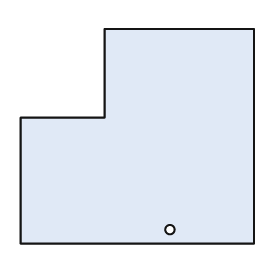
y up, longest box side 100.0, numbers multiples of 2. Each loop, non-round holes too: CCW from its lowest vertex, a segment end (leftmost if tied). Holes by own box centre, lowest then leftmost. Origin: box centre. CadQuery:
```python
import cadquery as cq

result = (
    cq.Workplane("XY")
    .moveTo(-50.0, -46.0)
    .lineTo(50.0, -46.0)
    .lineTo(50.0, 46.0)
    .lineTo(-14.0, 46.0)
    .lineTo(-14.0, 8.0)
    .lineTo(-50.0, 8.0)
    .close()
    .moveTo(14.0, -40.0)
    .circle(2.0)
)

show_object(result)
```